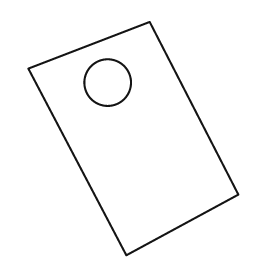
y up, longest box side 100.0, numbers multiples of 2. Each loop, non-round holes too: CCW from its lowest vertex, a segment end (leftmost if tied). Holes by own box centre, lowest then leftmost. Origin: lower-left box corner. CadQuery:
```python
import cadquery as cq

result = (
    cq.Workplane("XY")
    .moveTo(42.0, 0.0)
    .lineTo(90.0, 26.0)
    .lineTo(52.0, 100.0)
    .lineTo(0.0, 80.0)
    .close()
    .moveTo(34.0, 74.0)
    .circle(10.0)
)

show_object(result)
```